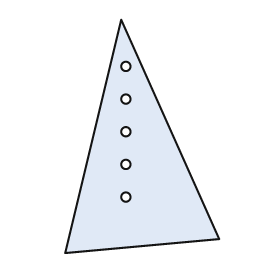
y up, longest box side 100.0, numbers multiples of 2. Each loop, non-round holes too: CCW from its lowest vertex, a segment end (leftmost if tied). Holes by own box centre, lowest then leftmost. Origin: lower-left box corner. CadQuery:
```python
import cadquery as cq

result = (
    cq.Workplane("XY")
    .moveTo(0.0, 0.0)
    .lineTo(66.0, 6.0)
    .lineTo(24.0, 100.0)
    .close()
    .moveTo(26.0, 24.0)
    .circle(2.0)
    .moveTo(26.0, 38.0)
    .circle(2.0)
    .moveTo(26.0, 52.0)
    .circle(2.0)
    .moveTo(26.0, 66.0)
    .circle(2.0)
    .moveTo(26.0, 80.0)
    .circle(2.0)
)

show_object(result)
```